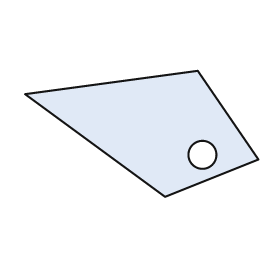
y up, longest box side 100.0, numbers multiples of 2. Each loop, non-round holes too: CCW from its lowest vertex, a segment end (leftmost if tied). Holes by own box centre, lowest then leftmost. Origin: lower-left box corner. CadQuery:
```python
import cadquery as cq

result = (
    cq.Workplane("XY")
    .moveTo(60.0, 0.0)
    .lineTo(100.0, 16.0)
    .lineTo(74.0, 54.0)
    .lineTo(0.0, 44.0)
    .close()
    .moveTo(76.0, 18.0)
    .circle(6.0)
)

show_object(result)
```